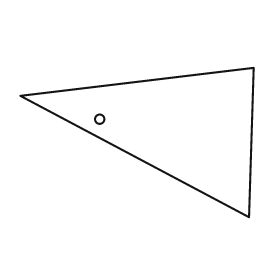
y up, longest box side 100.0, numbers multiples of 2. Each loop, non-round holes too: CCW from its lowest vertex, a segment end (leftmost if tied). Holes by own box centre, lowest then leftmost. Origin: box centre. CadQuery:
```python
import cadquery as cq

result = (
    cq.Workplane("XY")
    .moveTo(48.0, -32.0)
    .lineTo(50.0, 32.0)
    .lineTo(-50.0, 20.0)
    .close()
    .moveTo(-16.0, 10.0)
    .circle(2.0)
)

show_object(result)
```